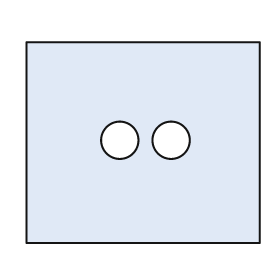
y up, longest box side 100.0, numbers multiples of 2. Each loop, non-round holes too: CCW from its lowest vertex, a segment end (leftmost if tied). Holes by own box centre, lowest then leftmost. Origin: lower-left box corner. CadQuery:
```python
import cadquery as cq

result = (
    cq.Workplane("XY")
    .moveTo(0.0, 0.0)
    .lineTo(100.0, 0.0)
    .lineTo(100.0, 86.0)
    .lineTo(0.0, 86.0)
    .close()
    .moveTo(40.0, 44.0)
    .circle(8.0)
    .moveTo(62.0, 44.0)
    .circle(8.0)
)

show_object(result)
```